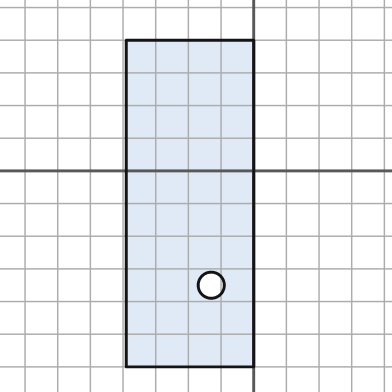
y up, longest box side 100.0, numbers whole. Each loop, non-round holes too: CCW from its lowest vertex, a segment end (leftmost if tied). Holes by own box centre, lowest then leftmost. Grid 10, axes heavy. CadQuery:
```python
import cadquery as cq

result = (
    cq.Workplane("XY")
    .moveTo(-39.0, -60.0)
    .lineTo(0.0, -60.0)
    .lineTo(0.0, 40.0)
    .lineTo(-39.0, 40.0)
    .close()
    .moveTo(-13.0, -35.0)
    .circle(4.0)
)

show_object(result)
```